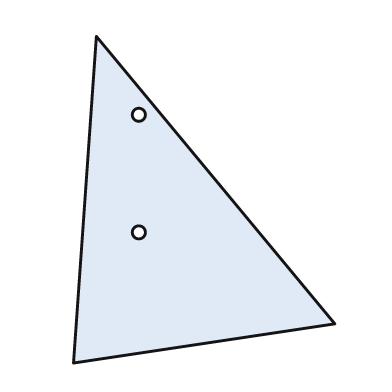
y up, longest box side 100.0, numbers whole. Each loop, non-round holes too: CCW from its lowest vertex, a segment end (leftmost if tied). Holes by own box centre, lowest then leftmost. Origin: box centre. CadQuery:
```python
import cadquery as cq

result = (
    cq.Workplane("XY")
    .moveTo(-40.0, -50.0)
    .lineTo(40.0, -38.0)
    .lineTo(-33.0, 50.0)
    .close()
    .moveTo(-20.0, -10.0)
    .circle(2.0)
    .moveTo(-20.0, 26.0)
    .circle(2.0)
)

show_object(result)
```